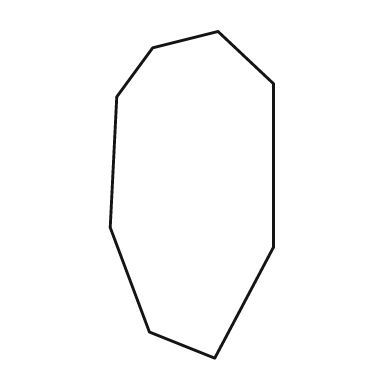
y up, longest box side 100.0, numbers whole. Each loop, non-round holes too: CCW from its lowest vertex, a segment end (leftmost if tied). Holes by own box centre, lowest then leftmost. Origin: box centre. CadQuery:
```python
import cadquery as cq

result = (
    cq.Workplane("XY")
    .moveTo(7.0, -50.0)
    .lineTo(25.0, -16.0)
    .lineTo(25.0, 34.0)
    .lineTo(8.0, 50.0)
    .lineTo(-12.0, 45.0)
    .lineTo(-23.0, 30.0)
    .lineTo(-25.0, -10.0)
    .lineTo(-13.0, -42.0)
    .close()
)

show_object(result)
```